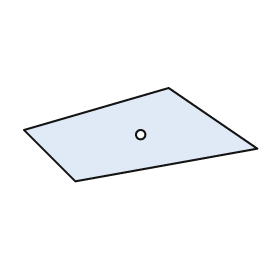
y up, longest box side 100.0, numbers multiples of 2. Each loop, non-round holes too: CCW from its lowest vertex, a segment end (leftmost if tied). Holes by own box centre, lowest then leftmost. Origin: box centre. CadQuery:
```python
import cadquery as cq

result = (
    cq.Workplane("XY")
    .moveTo(-28.0, -20.0)
    .lineTo(50.0, -6.0)
    .lineTo(12.0, 20.0)
    .lineTo(-50.0, 2.0)
    .close()
    .moveTo(0.0, 0.0)
    .circle(2.0)
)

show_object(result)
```